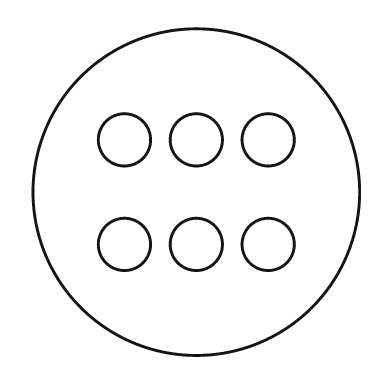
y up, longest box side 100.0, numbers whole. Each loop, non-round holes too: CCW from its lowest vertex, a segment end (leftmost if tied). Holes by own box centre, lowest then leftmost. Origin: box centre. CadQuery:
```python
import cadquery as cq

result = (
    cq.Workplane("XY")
    .moveTo(0.0, 0.0)
    .circle(50.0)
    .moveTo(-22.0, -16.0)
    .circle(8.0)
    .moveTo(0.0, -16.0)
    .circle(8.0)
    .moveTo(22.0, -16.0)
    .circle(8.0)
    .moveTo(-22.0, 16.0)
    .circle(8.0)
    .moveTo(0.0, 16.0)
    .circle(8.0)
    .moveTo(22.0, 16.0)
    .circle(8.0)
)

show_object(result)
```